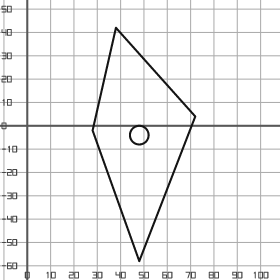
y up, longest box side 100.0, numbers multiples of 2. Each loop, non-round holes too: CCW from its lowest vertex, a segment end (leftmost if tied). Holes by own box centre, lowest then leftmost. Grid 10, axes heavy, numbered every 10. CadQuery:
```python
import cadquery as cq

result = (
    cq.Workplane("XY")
    .moveTo(48.0, -58.0)
    .lineTo(72.0, 4.0)
    .lineTo(38.0, 42.0)
    .lineTo(28.0, -2.0)
    .close()
    .moveTo(48.0, -4.0)
    .circle(4.0)
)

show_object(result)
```